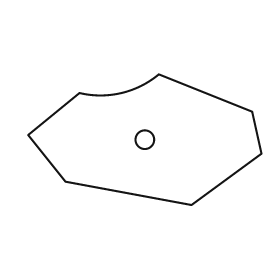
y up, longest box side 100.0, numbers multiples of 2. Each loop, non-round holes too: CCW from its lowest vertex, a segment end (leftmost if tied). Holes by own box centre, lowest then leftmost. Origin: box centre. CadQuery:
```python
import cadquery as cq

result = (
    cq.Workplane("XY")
    .moveTo(20.0, -28.0)
    .lineTo(50.0, -6.0)
    .lineTo(46.0, 12.0)
    .lineTo(6.0, 28.0)
    .threePointArc((-10.0, 20.0), (-28.0, 20.0))
    .lineTo(-50.0, 2.0)
    .lineTo(-34.0, -18.0)
    .close()
    .moveTo(0.0, 0.0)
    .circle(4.0)
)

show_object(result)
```